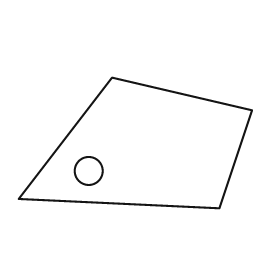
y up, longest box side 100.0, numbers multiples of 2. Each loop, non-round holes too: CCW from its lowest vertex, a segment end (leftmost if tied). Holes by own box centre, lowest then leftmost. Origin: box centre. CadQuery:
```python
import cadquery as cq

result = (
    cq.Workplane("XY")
    .moveTo(36.0, -28.0)
    .lineTo(50.0, 14.0)
    .lineTo(-10.0, 28.0)
    .lineTo(-50.0, -24.0)
    .close()
    .moveTo(-20.0, -12.0)
    .circle(6.0)
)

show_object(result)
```